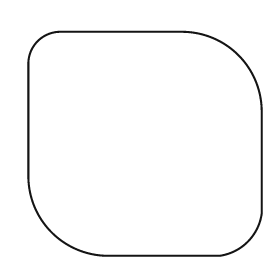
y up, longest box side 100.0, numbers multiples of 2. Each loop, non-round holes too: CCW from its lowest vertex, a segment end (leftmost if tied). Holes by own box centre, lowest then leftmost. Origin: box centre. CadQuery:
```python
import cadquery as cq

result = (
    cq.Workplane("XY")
    .moveTo(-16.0, -48.0)
    .lineTo(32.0, -48.0)
    .threePointArc((44.0, -42.0), (50.0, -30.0))
    .lineTo(50.0, 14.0)
    .threePointArc((40.0, 38.0), (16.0, 48.0))
    .lineTo(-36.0, 48.0)
    .threePointArc((-46.0, 44.0), (-50.0, 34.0))
    .lineTo(-50.0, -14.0)
    .threePointArc((-40.0, -38.0), (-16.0, -48.0))
    .close()
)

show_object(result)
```